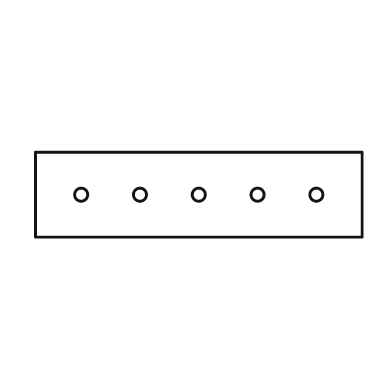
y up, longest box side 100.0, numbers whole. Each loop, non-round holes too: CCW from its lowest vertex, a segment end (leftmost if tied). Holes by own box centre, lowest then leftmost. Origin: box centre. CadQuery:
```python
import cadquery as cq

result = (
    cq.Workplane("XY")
    .moveTo(-50.0, -13.0)
    .lineTo(50.0, -13.0)
    .lineTo(50.0, 13.0)
    .lineTo(-50.0, 13.0)
    .close()
    .moveTo(-36.0, 0.0)
    .circle(2.0)
    .moveTo(-18.0, 0.0)
    .circle(2.0)
    .moveTo(0.0, 0.0)
    .circle(2.0)
    .moveTo(18.0, 0.0)
    .circle(2.0)
    .moveTo(36.0, 0.0)
    .circle(2.0)
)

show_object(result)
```